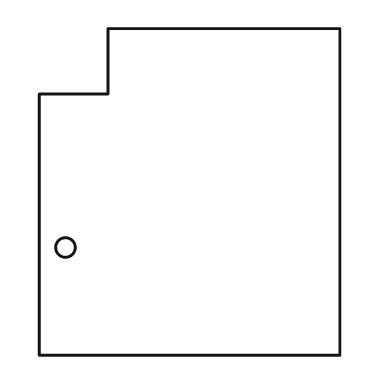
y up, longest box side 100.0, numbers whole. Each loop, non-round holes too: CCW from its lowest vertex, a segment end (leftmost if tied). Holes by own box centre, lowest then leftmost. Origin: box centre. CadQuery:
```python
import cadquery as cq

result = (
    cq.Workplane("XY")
    .moveTo(-46.0, -50.0)
    .lineTo(46.0, -50.0)
    .lineTo(46.0, 50.0)
    .lineTo(-25.0, 50.0)
    .lineTo(-25.0, 30.0)
    .lineTo(-46.0, 30.0)
    .close()
    .moveTo(-38.0, -17.0)
    .circle(3.0)
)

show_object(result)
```